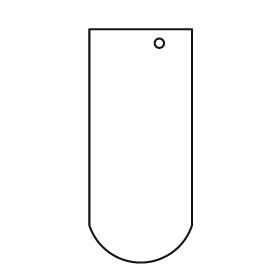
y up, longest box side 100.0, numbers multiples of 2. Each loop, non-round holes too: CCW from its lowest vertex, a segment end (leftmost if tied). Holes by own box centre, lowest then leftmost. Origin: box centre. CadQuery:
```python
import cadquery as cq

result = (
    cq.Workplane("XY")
    .moveTo(-22.0, -34.0)
    .threePointArc((0.0, -50.0), (22.0, -34.0))
    .lineTo(22.0, 50.0)
    .lineTo(-22.0, 50.0)
    .close()
    .moveTo(8.0, 44.0)
    .circle(2.0)
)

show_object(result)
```